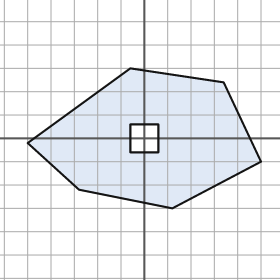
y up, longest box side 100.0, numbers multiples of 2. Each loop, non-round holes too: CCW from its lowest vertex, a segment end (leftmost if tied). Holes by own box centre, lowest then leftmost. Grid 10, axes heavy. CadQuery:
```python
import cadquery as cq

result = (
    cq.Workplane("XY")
    .moveTo(12.0, -30.0)
    .lineTo(50.0, -10.0)
    .lineTo(34.0, 24.0)
    .lineTo(-6.0, 30.0)
    .lineTo(-50.0, -2.0)
    .lineTo(-28.0, -22.0)
    .close()
    .moveTo(-6.0, -6.0)
    .lineTo(6.0, -6.0)
    .lineTo(6.0, 6.0)
    .lineTo(-6.0, 6.0)
    .close()
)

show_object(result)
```